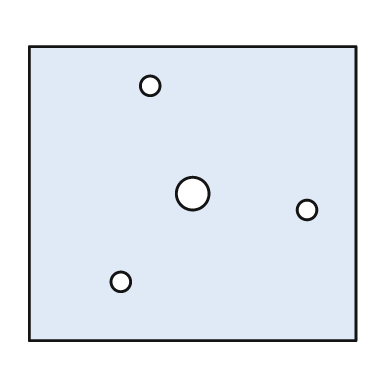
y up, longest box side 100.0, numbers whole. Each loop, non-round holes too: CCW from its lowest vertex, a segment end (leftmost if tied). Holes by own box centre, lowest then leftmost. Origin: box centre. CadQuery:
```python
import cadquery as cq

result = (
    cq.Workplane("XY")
    .moveTo(-50.0, -45.0)
    .lineTo(50.0, -45.0)
    .lineTo(50.0, 45.0)
    .lineTo(-50.0, 45.0)
    .close()
    .moveTo(-22.0, -27.0)
    .circle(3.0)
    .moveTo(35.0, -5.0)
    .circle(3.0)
    .moveTo(0.0, 0.0)
    .circle(5.0)
    .moveTo(-13.0, 33.0)
    .circle(3.0)
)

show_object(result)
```